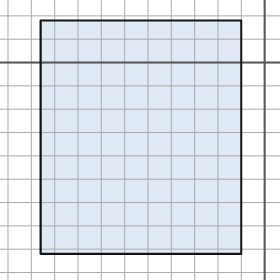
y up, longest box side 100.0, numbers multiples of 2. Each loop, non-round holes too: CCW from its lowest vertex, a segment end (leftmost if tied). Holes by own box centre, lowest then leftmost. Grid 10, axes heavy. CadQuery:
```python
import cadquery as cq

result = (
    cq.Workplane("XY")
    .moveTo(-96.0, -82.0)
    .lineTo(-10.0, -82.0)
    .lineTo(-10.0, 18.0)
    .lineTo(-96.0, 18.0)
    .close()
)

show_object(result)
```